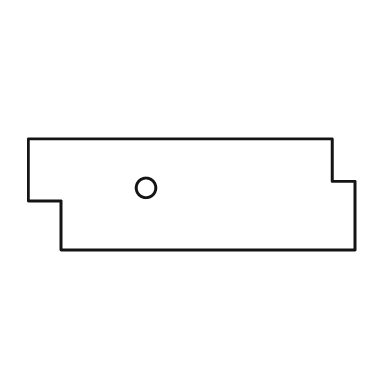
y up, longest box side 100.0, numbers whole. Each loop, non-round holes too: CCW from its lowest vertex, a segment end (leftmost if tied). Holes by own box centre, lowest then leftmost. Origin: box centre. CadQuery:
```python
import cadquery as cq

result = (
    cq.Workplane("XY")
    .moveTo(-40.0, -17.0)
    .lineTo(50.0, -17.0)
    .lineTo(50.0, 4.0)
    .lineTo(43.0, 4.0)
    .lineTo(43.0, 17.0)
    .lineTo(-50.0, 17.0)
    .lineTo(-50.0, -2.0)
    .lineTo(-40.0, -2.0)
    .close()
    .moveTo(-14.0, 2.0)
    .circle(3.0)
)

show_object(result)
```